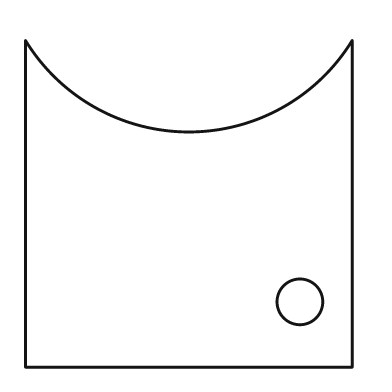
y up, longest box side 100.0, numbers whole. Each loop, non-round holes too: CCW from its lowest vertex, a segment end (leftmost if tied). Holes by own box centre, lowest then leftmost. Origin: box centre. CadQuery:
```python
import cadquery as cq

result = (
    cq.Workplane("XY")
    .moveTo(-50.0, -50.0)
    .lineTo(50.0, -50.0)
    .lineTo(50.0, 50.0)
    .threePointArc((0.0, 22.0), (-50.0, 50.0))
    .close()
    .moveTo(34.0, -30.0)
    .circle(7.0)
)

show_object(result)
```